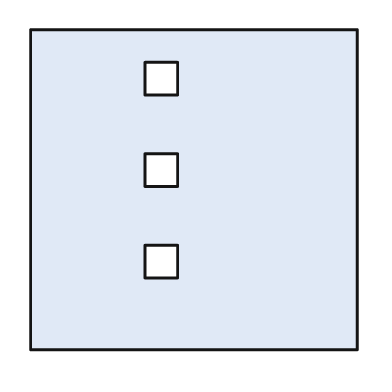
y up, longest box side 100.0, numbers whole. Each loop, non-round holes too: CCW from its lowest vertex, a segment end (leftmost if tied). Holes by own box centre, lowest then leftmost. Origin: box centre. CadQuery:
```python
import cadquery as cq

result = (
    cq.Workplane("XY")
    .moveTo(-50.0, -49.0)
    .lineTo(50.0, -49.0)
    .lineTo(50.0, 49.0)
    .lineTo(-50.0, 49.0)
    .close()
    .moveTo(-15.0, -27.0)
    .lineTo(-5.0, -27.0)
    .lineTo(-5.0, -17.0)
    .lineTo(-15.0, -17.0)
    .close()
    .moveTo(-15.0, 1.0)
    .lineTo(-5.0, 1.0)
    .lineTo(-5.0, 11.0)
    .lineTo(-15.0, 11.0)
    .close()
    .moveTo(-15.0, 29.0)
    .lineTo(-5.0, 29.0)
    .lineTo(-5.0, 39.0)
    .lineTo(-15.0, 39.0)
    .close()
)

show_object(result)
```